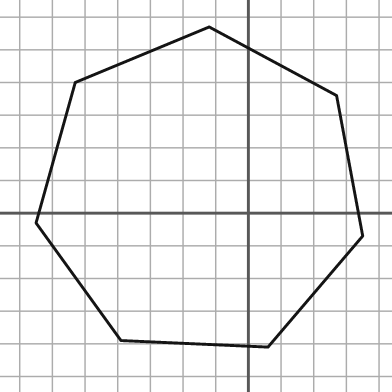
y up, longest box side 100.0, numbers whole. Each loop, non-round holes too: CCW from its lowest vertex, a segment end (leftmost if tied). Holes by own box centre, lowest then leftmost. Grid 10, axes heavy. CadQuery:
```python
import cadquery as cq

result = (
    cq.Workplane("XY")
    .moveTo(6.0, -41.0)
    .lineTo(35.0, -7.0)
    .lineTo(27.0, 36.0)
    .lineTo(-12.0, 57.0)
    .lineTo(-53.0, 40.0)
    .lineTo(-65.0, -3.0)
    .lineTo(-39.0, -39.0)
    .close()
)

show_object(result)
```